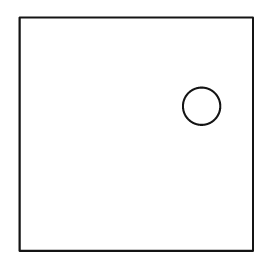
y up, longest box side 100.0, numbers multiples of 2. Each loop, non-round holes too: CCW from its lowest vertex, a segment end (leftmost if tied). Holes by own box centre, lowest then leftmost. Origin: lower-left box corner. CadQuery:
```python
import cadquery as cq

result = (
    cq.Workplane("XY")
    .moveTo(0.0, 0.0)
    .lineTo(100.0, 0.0)
    .lineTo(100.0, 100.0)
    .lineTo(0.0, 100.0)
    .close()
    .moveTo(78.0, 62.0)
    .circle(8.0)
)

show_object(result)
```